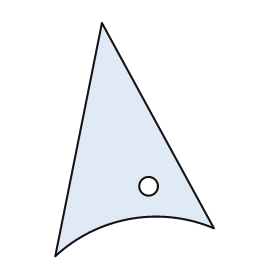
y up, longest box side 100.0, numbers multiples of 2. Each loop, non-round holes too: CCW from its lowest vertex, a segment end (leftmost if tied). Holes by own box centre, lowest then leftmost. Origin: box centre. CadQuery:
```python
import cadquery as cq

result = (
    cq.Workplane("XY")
    .moveTo(-34.0, -50.0)
    .threePointArc((-2.0, -34.0), (34.0, -38.0))
    .lineTo(-14.0, 50.0)
    .close()
    .moveTo(6.0, -20.0)
    .circle(4.0)
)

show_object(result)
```